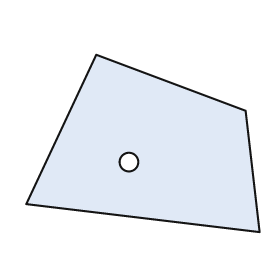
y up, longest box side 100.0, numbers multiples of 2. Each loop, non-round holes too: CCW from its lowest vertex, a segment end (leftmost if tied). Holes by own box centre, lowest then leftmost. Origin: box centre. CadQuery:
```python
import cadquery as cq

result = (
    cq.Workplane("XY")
    .moveTo(50.0, -38.0)
    .lineTo(44.0, 14.0)
    .lineTo(-20.0, 38.0)
    .lineTo(-50.0, -26.0)
    .close()
    .moveTo(-6.0, -8.0)
    .circle(4.0)
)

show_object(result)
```